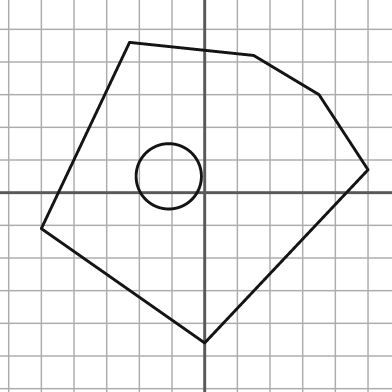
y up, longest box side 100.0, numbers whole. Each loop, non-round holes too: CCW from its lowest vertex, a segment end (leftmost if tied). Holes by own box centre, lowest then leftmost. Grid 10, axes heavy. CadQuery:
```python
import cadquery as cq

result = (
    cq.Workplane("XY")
    .moveTo(0.0, -46.0)
    .lineTo(50.0, 7.0)
    .lineTo(35.0, 30.0)
    .lineTo(15.0, 42.0)
    .lineTo(-23.0, 46.0)
    .lineTo(-50.0, -11.0)
    .close()
    .moveTo(-11.0, 5.0)
    .circle(10.0)
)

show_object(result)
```